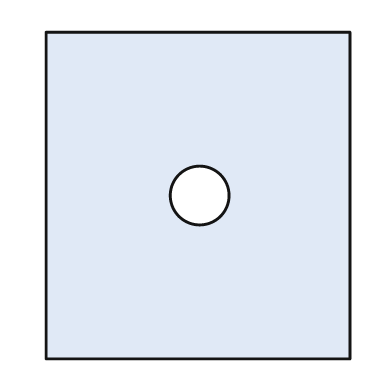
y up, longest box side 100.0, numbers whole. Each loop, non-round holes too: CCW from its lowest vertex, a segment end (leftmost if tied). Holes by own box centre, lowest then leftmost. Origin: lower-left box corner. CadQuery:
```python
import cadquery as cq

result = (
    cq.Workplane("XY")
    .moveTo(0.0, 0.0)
    .lineTo(93.0, 0.0)
    .lineTo(93.0, 100.0)
    .lineTo(0.0, 100.0)
    .close()
    .moveTo(47.0, 50.0)
    .circle(9.0)
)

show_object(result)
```